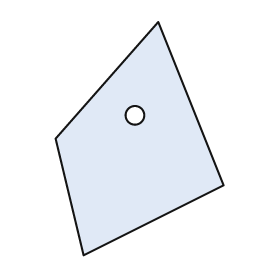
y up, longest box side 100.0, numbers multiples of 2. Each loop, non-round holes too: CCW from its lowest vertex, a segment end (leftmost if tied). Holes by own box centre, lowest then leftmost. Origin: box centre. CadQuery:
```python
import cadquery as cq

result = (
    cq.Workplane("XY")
    .moveTo(-24.0, -50.0)
    .lineTo(36.0, -20.0)
    .lineTo(8.0, 50.0)
    .lineTo(-36.0, 0.0)
    .close()
    .moveTo(-2.0, 10.0)
    .circle(4.0)
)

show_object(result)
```